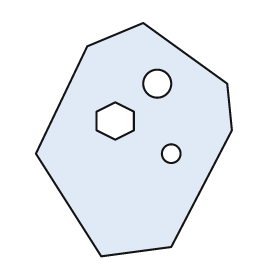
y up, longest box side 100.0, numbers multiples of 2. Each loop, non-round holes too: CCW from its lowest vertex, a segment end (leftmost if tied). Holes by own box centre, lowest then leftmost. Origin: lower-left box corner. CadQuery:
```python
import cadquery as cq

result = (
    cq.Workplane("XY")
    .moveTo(28.0, 0.0)
    .lineTo(58.0, 4.0)
    .lineTo(84.0, 54.0)
    .lineTo(82.0, 74.0)
    .lineTo(46.0, 100.0)
    .lineTo(22.0, 90.0)
    .lineTo(0.0, 44.0)
    .close()
    .moveTo(58.0, 44.0)
    .circle(4.0)
    .moveTo(34.0, 50.0)
    .lineTo(42.0, 54.0)
    .lineTo(42.0, 62.0)
    .lineTo(34.0, 66.0)
    .lineTo(26.0, 62.0)
    .lineTo(26.0, 54.0)
    .close()
    .moveTo(52.0, 74.0)
    .circle(6.0)
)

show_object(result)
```